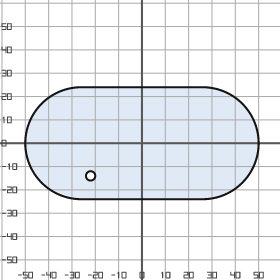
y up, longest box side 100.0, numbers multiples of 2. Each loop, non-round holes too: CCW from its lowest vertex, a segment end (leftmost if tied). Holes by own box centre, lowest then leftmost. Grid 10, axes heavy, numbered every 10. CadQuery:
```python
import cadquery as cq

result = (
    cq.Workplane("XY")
    .moveTo(-26.0, -24.0)
    .lineTo(26.0, -24.0)
    .threePointArc((50.0, 0.0), (26.0, 24.0))
    .lineTo(-26.0, 24.0)
    .threePointArc((-50.0, 0.0), (-26.0, -24.0))
    .close()
    .moveTo(-22.0, -14.0)
    .circle(2.0)
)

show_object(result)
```